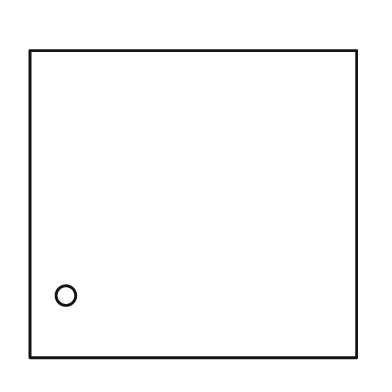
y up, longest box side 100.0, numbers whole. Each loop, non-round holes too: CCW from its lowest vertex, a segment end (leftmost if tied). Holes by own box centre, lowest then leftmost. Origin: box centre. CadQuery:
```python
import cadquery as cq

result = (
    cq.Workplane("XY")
    .moveTo(-50.0, -47.0)
    .lineTo(50.0, -47.0)
    .lineTo(50.0, 47.0)
    .lineTo(-50.0, 47.0)
    .close()
    .moveTo(-39.0, -28.0)
    .circle(3.0)
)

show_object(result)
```